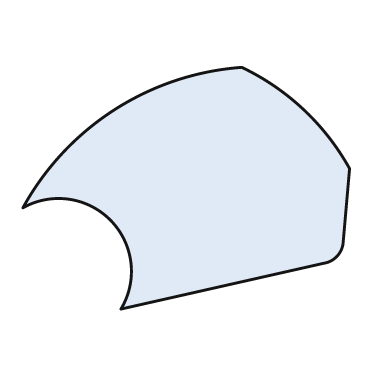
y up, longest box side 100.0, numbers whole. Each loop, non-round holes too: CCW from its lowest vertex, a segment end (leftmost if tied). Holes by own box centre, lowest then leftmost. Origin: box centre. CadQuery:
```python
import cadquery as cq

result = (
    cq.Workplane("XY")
    .moveTo(-20.0, -37.0)
    .lineTo(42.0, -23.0)
    .threePointArc((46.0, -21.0), (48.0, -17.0))
    .lineTo(50.0, 6.0)
    .threePointArc((36.0, 24.0), (17.0, 37.0))
    .threePointArc((-22.0, 24.0), (-50.0, -6.0))
    .threePointArc((-23.0, -10.0), (-20.0, -37.0))
    .close()
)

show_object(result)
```